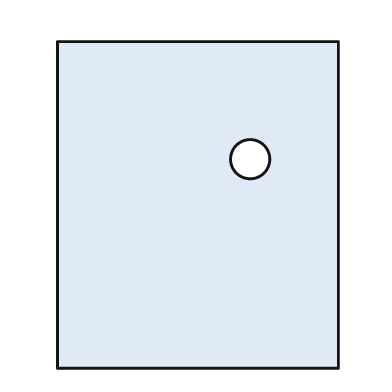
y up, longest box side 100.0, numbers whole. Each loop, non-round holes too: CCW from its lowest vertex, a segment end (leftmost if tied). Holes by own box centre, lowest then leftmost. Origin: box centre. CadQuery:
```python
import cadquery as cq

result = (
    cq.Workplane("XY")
    .moveTo(-43.0, -50.0)
    .lineTo(43.0, -50.0)
    .lineTo(43.0, 50.0)
    .lineTo(-43.0, 50.0)
    .close()
    .moveTo(16.0, 14.0)
    .circle(6.0)
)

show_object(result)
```